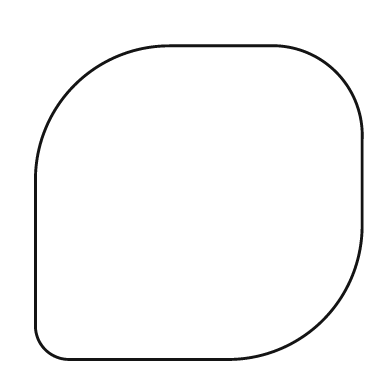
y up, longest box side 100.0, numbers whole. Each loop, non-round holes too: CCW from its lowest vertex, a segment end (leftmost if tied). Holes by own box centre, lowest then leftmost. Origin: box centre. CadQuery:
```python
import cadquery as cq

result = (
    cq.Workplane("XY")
    .moveTo(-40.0, -48.0)
    .lineTo(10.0, -48.0)
    .threePointArc((38.0, -36.0), (50.0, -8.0))
    .lineTo(50.0, 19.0)
    .threePointArc((42.0, 40.0), (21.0, 48.0))
    .lineTo(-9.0, 48.0)
    .threePointArc((-38.0, 36.0), (-50.0, 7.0))
    .lineTo(-50.0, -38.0)
    .threePointArc((-47.0, -45.0), (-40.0, -48.0))
    .close()
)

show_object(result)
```